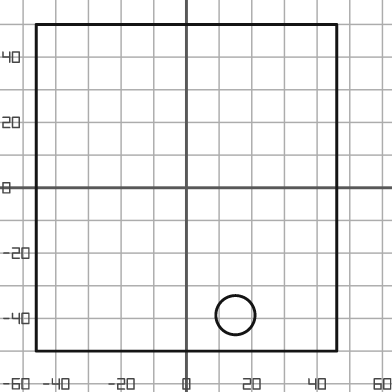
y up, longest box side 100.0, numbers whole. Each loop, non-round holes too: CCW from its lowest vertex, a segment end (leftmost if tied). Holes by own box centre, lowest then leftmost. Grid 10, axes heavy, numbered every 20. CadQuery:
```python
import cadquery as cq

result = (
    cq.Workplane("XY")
    .moveTo(-46.0, -50.0)
    .lineTo(46.0, -50.0)
    .lineTo(46.0, 50.0)
    .lineTo(-46.0, 50.0)
    .close()
    .moveTo(15.0, -39.0)
    .circle(6.0)
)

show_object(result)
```